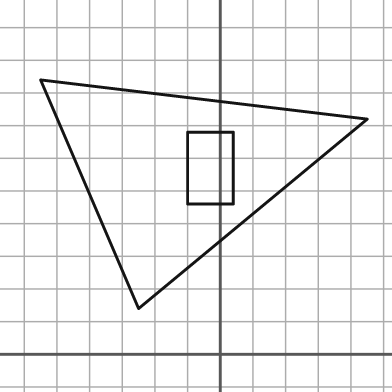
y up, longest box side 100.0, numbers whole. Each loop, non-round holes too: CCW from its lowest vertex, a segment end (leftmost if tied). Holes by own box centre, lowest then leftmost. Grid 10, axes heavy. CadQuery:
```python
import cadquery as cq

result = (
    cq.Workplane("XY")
    .moveTo(-25.0, 14.0)
    .lineTo(45.0, 72.0)
    .lineTo(-55.0, 84.0)
    .close()
    .moveTo(-10.0, 46.0)
    .lineTo(4.0, 46.0)
    .lineTo(4.0, 68.0)
    .lineTo(-10.0, 68.0)
    .close()
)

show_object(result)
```